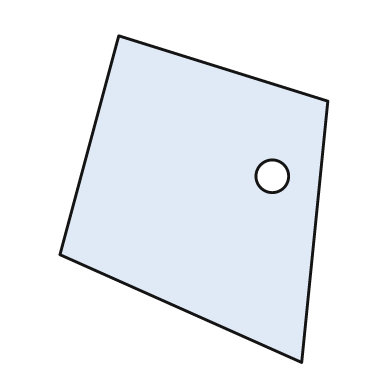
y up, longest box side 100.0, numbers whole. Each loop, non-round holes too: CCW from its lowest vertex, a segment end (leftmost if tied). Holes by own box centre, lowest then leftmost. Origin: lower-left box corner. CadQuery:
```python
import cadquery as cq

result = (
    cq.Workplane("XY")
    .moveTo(74.0, 0.0)
    .lineTo(82.0, 80.0)
    .lineTo(18.0, 100.0)
    .lineTo(0.0, 33.0)
    .close()
    .moveTo(65.0, 57.0)
    .circle(5.0)
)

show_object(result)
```